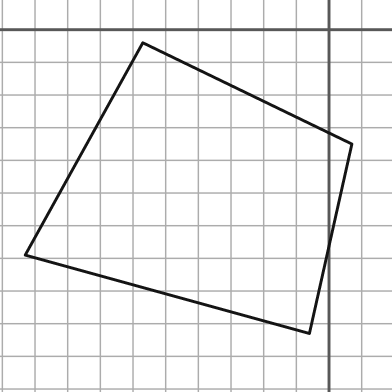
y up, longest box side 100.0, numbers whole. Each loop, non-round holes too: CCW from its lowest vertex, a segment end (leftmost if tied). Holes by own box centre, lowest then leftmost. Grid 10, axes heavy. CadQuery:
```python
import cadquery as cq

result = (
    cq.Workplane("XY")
    .moveTo(-6.0, -93.0)
    .lineTo(7.0, -35.0)
    .lineTo(-57.0, -4.0)
    .lineTo(-93.0, -69.0)
    .close()
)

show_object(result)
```